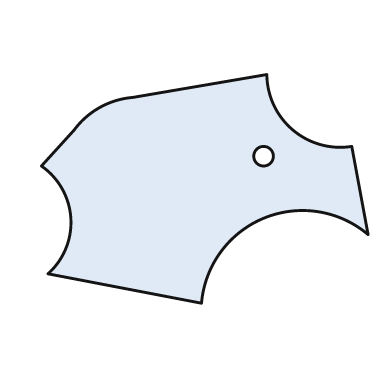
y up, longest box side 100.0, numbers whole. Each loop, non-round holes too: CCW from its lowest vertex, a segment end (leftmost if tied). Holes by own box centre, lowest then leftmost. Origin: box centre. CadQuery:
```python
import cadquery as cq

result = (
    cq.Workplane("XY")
    .moveTo(-1.0, -35.0)
    .threePointArc((18.0, -9.0), (50.0, -14.0))
    .lineTo(45.0, 13.0)
    .threePointArc((27.0, 18.0), (19.0, 35.0))
    .lineTo(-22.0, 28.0)
    .threePointArc((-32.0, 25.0), (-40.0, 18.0))
    .lineTo(-50.0, 7.0)
    .threePointArc((-41.0, -9.0), (-48.0, -26.0))
    .close()
    .moveTo(18.0, 10.0)
    .circle(3.0)
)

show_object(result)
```